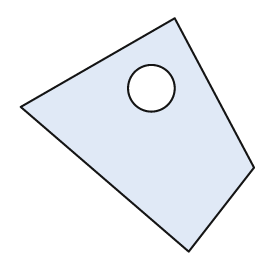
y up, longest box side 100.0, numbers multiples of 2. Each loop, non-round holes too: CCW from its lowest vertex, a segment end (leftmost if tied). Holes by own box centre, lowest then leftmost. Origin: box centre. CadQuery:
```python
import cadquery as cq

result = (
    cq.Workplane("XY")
    .moveTo(22.0, -50.0)
    .lineTo(50.0, -14.0)
    .lineTo(16.0, 50.0)
    .lineTo(-50.0, 12.0)
    .close()
    .moveTo(6.0, 20.0)
    .circle(10.0)
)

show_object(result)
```